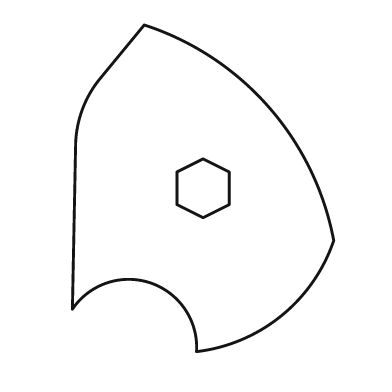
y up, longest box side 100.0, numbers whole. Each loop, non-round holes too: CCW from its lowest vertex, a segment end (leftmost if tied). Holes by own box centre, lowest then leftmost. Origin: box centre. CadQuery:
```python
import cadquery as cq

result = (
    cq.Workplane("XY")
    .moveTo(-2.0, -50.0)
    .threePointArc((24.0, -39.0), (40.0, -16.0))
    .threePointArc((20.0, 25.0), (-18.0, 50.0))
    .lineTo(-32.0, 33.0)
    .threePointArc((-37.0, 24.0), (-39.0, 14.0))
    .lineTo(-40.0, -37.0)
    .threePointArc((-16.0, -29.0), (-2.0, -50.0))
    .close()
    .moveTo(0.0, -9.0)
    .lineTo(8.0, -5.0)
    .lineTo(8.0, 5.0)
    .lineTo(0.0, 9.0)
    .lineTo(-8.0, 5.0)
    .lineTo(-8.0, -5.0)
    .close()
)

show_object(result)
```